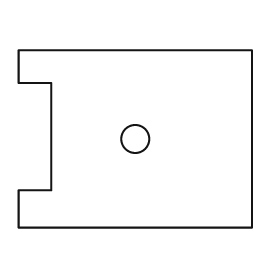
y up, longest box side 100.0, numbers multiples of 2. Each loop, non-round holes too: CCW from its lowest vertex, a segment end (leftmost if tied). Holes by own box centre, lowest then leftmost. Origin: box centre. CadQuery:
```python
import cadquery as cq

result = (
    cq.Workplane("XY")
    .moveTo(-50.0, -38.0)
    .lineTo(50.0, -38.0)
    .lineTo(50.0, 38.0)
    .lineTo(-50.0, 38.0)
    .lineTo(-50.0, 24.0)
    .lineTo(-36.0, 24.0)
    .lineTo(-36.0, -22.0)
    .lineTo(-50.0, -22.0)
    .close()
    .moveTo(0.0, 0.0)
    .circle(6.0)
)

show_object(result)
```